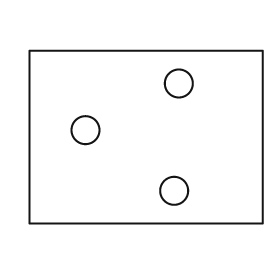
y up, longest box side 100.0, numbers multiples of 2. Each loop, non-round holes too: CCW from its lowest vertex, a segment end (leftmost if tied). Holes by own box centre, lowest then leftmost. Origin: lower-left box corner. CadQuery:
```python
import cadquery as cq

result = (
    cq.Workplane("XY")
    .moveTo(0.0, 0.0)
    .lineTo(100.0, 0.0)
    .lineTo(100.0, 74.0)
    .lineTo(0.0, 74.0)
    .close()
    .moveTo(62.0, 14.0)
    .circle(6.0)
    .moveTo(24.0, 40.0)
    .circle(6.0)
    .moveTo(64.0, 60.0)
    .circle(6.0)
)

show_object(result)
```